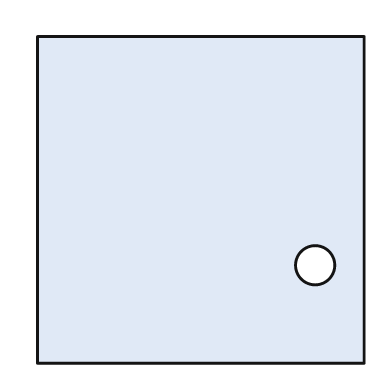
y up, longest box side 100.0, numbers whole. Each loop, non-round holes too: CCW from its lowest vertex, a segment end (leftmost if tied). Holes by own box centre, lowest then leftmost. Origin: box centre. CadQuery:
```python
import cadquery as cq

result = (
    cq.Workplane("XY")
    .moveTo(-50.0, -50.0)
    .lineTo(50.0, -50.0)
    .lineTo(50.0, 50.0)
    .lineTo(-50.0, 50.0)
    .close()
    .moveTo(35.0, -20.0)
    .circle(6.0)
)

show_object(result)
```